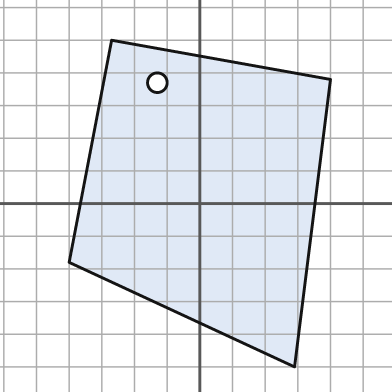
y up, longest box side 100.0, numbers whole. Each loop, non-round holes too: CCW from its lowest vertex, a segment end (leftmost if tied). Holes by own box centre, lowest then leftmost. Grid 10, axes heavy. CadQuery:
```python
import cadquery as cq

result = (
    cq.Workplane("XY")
    .moveTo(29.0, -50.0)
    .lineTo(40.0, 38.0)
    .lineTo(-27.0, 50.0)
    .lineTo(-40.0, -18.0)
    .close()
    .moveTo(-13.0, 37.0)
    .circle(3.0)
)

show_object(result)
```